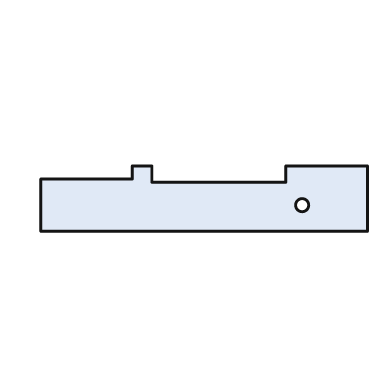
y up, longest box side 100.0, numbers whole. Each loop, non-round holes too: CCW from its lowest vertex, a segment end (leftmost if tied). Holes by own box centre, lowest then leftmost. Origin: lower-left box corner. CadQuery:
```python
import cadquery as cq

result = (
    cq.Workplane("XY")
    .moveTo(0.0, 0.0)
    .lineTo(100.0, 0.0)
    .lineTo(100.0, 20.0)
    .lineTo(75.0, 20.0)
    .lineTo(75.0, 15.0)
    .lineTo(34.0, 15.0)
    .lineTo(34.0, 20.0)
    .lineTo(28.0, 20.0)
    .lineTo(28.0, 16.0)
    .lineTo(0.0, 16.0)
    .close()
    .moveTo(80.0, 8.0)
    .circle(2.0)
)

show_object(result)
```